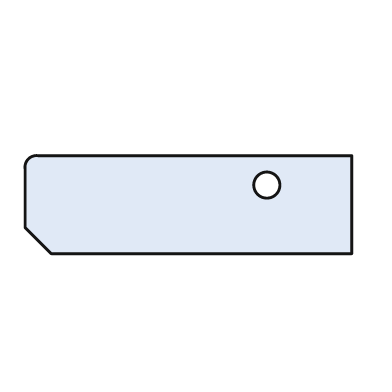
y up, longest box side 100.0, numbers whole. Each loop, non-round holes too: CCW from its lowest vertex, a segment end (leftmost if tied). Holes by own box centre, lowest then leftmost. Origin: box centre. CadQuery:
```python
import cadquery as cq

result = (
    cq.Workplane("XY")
    .moveTo(-42.0, -15.0)
    .lineTo(50.0, -15.0)
    .lineTo(50.0, 15.0)
    .lineTo(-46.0, 15.0)
    .threePointArc((-49.0, 14.0), (-50.0, 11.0))
    .lineTo(-50.0, -7.0)
    .close()
    .moveTo(24.0, 6.0)
    .circle(4.0)
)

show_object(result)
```